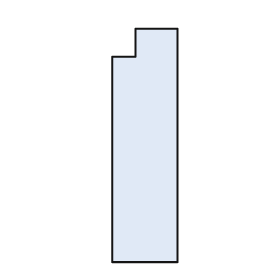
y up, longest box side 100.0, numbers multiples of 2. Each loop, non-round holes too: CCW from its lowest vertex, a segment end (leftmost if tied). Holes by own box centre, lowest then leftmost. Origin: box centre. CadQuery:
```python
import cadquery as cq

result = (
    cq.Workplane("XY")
    .moveTo(-14.0, -50.0)
    .lineTo(14.0, -50.0)
    .lineTo(14.0, 50.0)
    .lineTo(-4.0, 50.0)
    .lineTo(-4.0, 38.0)
    .lineTo(-14.0, 38.0)
    .close()
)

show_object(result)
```